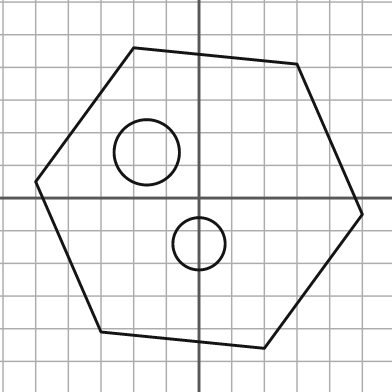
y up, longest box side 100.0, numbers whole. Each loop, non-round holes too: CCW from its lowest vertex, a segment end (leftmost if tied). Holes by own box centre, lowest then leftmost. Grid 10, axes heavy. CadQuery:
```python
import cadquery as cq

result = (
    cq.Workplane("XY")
    .moveTo(20.0, -46.0)
    .lineTo(50.0, -5.0)
    .lineTo(30.0, 41.0)
    .lineTo(-20.0, 46.0)
    .lineTo(-50.0, 5.0)
    .lineTo(-30.0, -41.0)
    .close()
    .moveTo(0.0, -14.0)
    .circle(8.0)
    .moveTo(-16.0, 14.0)
    .circle(10.0)
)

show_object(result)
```